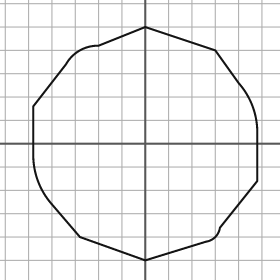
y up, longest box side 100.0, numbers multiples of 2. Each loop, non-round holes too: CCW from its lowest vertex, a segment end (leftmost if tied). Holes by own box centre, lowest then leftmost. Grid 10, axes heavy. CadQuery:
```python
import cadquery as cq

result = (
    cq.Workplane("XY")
    .moveTo(0.0, -50.0)
    .lineTo(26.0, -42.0)
    .threePointArc((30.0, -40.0), (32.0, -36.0))
    .lineTo(48.0, -16.0)
    .lineTo(48.0, 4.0)
    .threePointArc((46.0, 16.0), (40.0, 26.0))
    .lineTo(30.0, 40.0)
    .lineTo(0.0, 50.0)
    .lineTo(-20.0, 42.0)
    .threePointArc((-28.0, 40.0), (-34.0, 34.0))
    .lineTo(-48.0, 16.0)
    .lineTo(-48.0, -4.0)
    .threePointArc((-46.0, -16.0), (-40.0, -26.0))
    .lineTo(-28.0, -40.0)
    .close()
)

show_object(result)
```